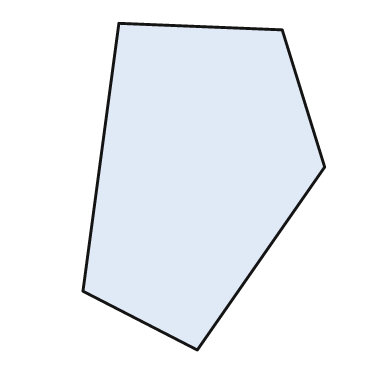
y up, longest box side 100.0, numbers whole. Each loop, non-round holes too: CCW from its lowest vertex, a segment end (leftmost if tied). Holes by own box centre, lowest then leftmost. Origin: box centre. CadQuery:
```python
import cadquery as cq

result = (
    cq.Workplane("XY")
    .moveTo(-2.0, -50.0)
    .lineTo(37.0, 6.0)
    .lineTo(24.0, 48.0)
    .lineTo(-26.0, 50.0)
    .lineTo(-37.0, -32.0)
    .close()
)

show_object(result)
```